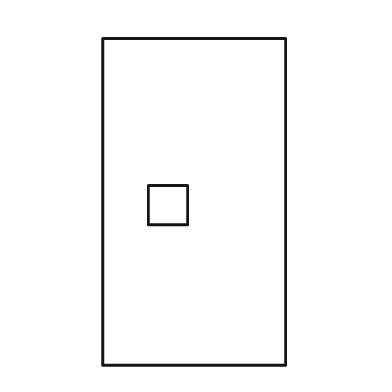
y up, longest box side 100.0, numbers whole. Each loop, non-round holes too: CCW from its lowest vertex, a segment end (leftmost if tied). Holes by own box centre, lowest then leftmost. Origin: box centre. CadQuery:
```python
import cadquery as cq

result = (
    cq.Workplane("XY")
    .moveTo(-28.0, -50.0)
    .lineTo(28.0, -50.0)
    .lineTo(28.0, 50.0)
    .lineTo(-28.0, 50.0)
    .close()
    .moveTo(-14.0, -7.0)
    .lineTo(-2.0, -7.0)
    .lineTo(-2.0, 5.0)
    .lineTo(-14.0, 5.0)
    .close()
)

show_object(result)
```